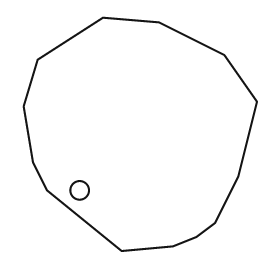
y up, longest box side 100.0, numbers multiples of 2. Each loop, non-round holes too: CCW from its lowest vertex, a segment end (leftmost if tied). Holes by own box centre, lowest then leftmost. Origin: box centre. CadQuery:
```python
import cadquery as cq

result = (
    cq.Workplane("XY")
    .moveTo(-8.0, -50.0)
    .lineTo(14.0, -48.0)
    .lineTo(24.0, -44.0)
    .lineTo(32.0, -38.0)
    .lineTo(42.0, -18.0)
    .lineTo(50.0, 14.0)
    .lineTo(36.0, 34.0)
    .lineTo(8.0, 48.0)
    .lineTo(-16.0, 50.0)
    .lineTo(-44.0, 32.0)
    .lineTo(-50.0, 12.0)
    .lineTo(-46.0, -12.0)
    .lineTo(-40.0, -24.0)
    .close()
    .moveTo(-26.0, -24.0)
    .circle(4.0)
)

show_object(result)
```